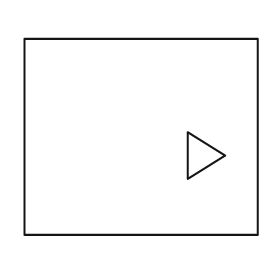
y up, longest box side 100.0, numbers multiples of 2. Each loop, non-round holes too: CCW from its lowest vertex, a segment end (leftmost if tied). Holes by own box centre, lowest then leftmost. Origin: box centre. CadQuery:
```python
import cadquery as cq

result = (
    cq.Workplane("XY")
    .moveTo(-50.0, -42.0)
    .lineTo(50.0, -42.0)
    .lineTo(50.0, 42.0)
    .lineTo(-50.0, 42.0)
    .close()
    .moveTo(20.0, -18.0)
    .lineTo(36.0, -8.0)
    .lineTo(20.0, 2.0)
    .close()
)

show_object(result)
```